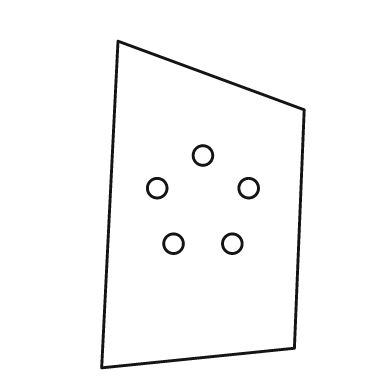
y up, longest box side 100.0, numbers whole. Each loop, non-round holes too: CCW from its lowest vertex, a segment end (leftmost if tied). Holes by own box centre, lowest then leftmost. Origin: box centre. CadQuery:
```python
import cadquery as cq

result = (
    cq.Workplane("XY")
    .moveTo(-31.0, -50.0)
    .lineTo(28.0, -44.0)
    .lineTo(31.0, 29.0)
    .lineTo(-26.0, 50.0)
    .close()
    .moveTo(-9.0, -12.0)
    .circle(3.0)
    .moveTo(9.0, -12.0)
    .circle(3.0)
    .moveTo(-14.0, 5.0)
    .circle(3.0)
    .moveTo(14.0, 5.0)
    .circle(3.0)
    .moveTo(0.0, 15.0)
    .circle(3.0)
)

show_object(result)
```